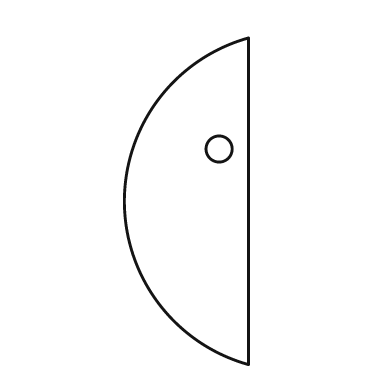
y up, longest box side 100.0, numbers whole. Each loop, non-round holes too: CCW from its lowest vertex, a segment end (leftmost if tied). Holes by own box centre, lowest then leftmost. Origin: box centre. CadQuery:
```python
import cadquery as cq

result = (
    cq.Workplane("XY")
    .moveTo(19.0, -50.0)
    .lineTo(19.0, 50.0)
    .threePointArc((-19.0, 0.0), (19.0, -50.0))
    .close()
    .moveTo(10.0, 16.0)
    .circle(4.0)
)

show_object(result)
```